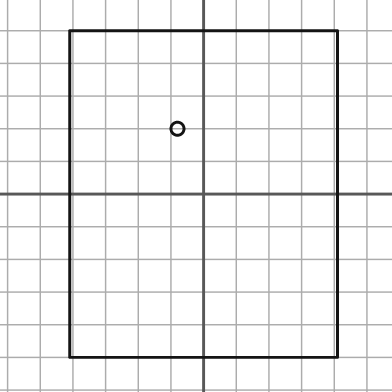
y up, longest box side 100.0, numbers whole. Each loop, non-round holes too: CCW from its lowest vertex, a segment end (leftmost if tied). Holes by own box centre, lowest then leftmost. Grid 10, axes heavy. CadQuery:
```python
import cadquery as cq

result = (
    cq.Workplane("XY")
    .moveTo(-41.0, -50.0)
    .lineTo(41.0, -50.0)
    .lineTo(41.0, 50.0)
    .lineTo(-41.0, 50.0)
    .close()
    .moveTo(-8.0, 20.0)
    .circle(2.0)
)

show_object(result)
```